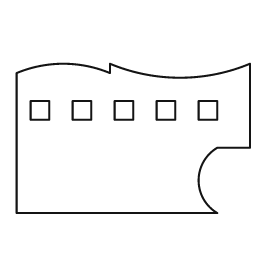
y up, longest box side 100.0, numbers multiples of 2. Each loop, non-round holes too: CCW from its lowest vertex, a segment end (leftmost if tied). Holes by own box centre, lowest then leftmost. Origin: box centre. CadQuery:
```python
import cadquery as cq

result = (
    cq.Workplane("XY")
    .moveTo(-50.0, -32.0)
    .lineTo(36.0, -32.0)
    .threePointArc((28.0, -18.0), (36.0, -4.0))
    .lineTo(50.0, -4.0)
    .lineTo(50.0, 32.0)
    .threePointArc((20.0, 26.0), (-10.0, 32.0))
    .lineTo(-10.0, 28.0)
    .threePointArc((-30.0, 32.0), (-50.0, 28.0))
    .close()
    .moveTo(-44.0, 8.0)
    .lineTo(-36.0, 8.0)
    .lineTo(-36.0, 16.0)
    .lineTo(-44.0, 16.0)
    .close()
    .moveTo(-26.0, 8.0)
    .lineTo(-18.0, 8.0)
    .lineTo(-18.0, 16.0)
    .lineTo(-26.0, 16.0)
    .close()
    .moveTo(-8.0, 8.0)
    .lineTo(0.0, 8.0)
    .lineTo(0.0, 16.0)
    .lineTo(-8.0, 16.0)
    .close()
    .moveTo(10.0, 8.0)
    .lineTo(18.0, 8.0)
    .lineTo(18.0, 16.0)
    .lineTo(10.0, 16.0)
    .close()
    .moveTo(28.0, 8.0)
    .lineTo(36.0, 8.0)
    .lineTo(36.0, 16.0)
    .lineTo(28.0, 16.0)
    .close()
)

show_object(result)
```